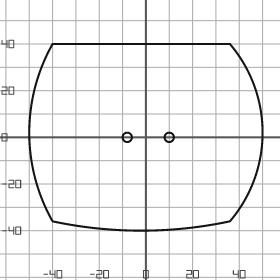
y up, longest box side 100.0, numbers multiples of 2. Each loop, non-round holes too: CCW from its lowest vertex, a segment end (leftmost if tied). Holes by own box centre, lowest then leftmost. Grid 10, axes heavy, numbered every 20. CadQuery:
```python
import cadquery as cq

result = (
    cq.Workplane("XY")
    .moveTo(-40.0, -36.0)
    .threePointArc((-2.0, -40.0), (36.0, -36.0))
    .threePointArc((50.0, 2.0), (36.0, 40.0))
    .lineTo(-40.0, 40.0)
    .threePointArc((-50.0, 2.0), (-40.0, -36.0))
    .close()
    .moveTo(-8.0, 0.0)
    .circle(2.0)
    .moveTo(10.0, 0.0)
    .circle(2.0)
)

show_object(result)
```